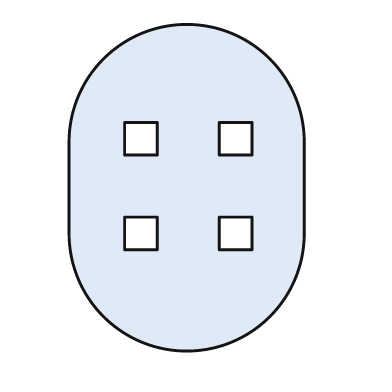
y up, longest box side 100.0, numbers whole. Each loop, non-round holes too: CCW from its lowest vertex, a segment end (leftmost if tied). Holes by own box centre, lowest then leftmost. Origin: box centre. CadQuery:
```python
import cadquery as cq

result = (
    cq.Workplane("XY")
    .moveTo(-36.0, -14.0)
    .threePointArc((0.0, -50.0), (36.0, -14.0))
    .lineTo(36.0, 14.0)
    .threePointArc((0.0, 50.0), (-36.0, 14.0))
    .close()
    .moveTo(-19.0, -19.0)
    .lineTo(-9.0, -19.0)
    .lineTo(-9.0, -9.0)
    .lineTo(-19.0, -9.0)
    .close()
    .moveTo(10.0, -19.0)
    .lineTo(20.0, -19.0)
    .lineTo(20.0, -9.0)
    .lineTo(10.0, -9.0)
    .close()
    .moveTo(-19.0, 10.0)
    .lineTo(-9.0, 10.0)
    .lineTo(-9.0, 20.0)
    .lineTo(-19.0, 20.0)
    .close()
    .moveTo(10.0, 10.0)
    .lineTo(20.0, 10.0)
    .lineTo(20.0, 20.0)
    .lineTo(10.0, 20.0)
    .close()
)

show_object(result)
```